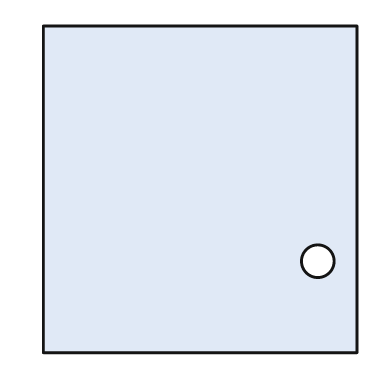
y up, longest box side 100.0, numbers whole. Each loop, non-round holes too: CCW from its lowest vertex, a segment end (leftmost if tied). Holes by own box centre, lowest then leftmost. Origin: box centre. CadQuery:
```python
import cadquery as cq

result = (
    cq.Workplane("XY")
    .moveTo(-48.0, -50.0)
    .lineTo(48.0, -50.0)
    .lineTo(48.0, 50.0)
    .lineTo(-48.0, 50.0)
    .close()
    .moveTo(36.0, -22.0)
    .circle(5.0)
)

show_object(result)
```